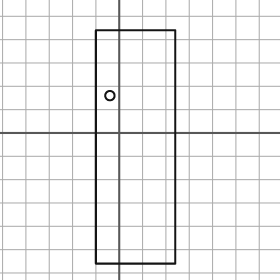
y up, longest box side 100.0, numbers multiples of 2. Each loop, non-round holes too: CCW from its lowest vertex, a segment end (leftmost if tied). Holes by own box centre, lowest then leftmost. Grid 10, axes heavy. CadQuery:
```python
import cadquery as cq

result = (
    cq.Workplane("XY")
    .moveTo(-10.0, -56.0)
    .lineTo(24.0, -56.0)
    .lineTo(24.0, 44.0)
    .lineTo(-10.0, 44.0)
    .close()
    .moveTo(-4.0, 16.0)
    .circle(2.0)
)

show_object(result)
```